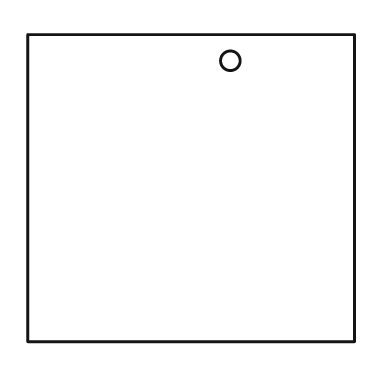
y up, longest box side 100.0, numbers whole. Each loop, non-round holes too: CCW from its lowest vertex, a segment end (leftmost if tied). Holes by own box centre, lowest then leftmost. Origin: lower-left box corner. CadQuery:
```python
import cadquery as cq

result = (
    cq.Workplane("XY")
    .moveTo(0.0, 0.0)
    .lineTo(100.0, 0.0)
    .lineTo(100.0, 94.0)
    .lineTo(0.0, 94.0)
    .close()
    .moveTo(62.0, 86.0)
    .circle(3.0)
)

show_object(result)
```